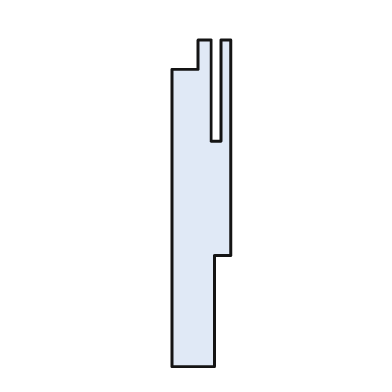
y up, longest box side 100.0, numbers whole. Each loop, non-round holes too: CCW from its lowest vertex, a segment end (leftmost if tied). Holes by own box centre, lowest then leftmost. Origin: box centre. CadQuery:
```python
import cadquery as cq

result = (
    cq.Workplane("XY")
    .moveTo(-9.0, -50.0)
    .lineTo(4.0, -50.0)
    .lineTo(4.0, -16.0)
    .lineTo(9.0, -16.0)
    .lineTo(9.0, 50.0)
    .lineTo(6.0, 50.0)
    .lineTo(6.0, 19.0)
    .lineTo(3.0, 19.0)
    .lineTo(3.0, 50.0)
    .lineTo(-1.0, 50.0)
    .lineTo(-1.0, 41.0)
    .lineTo(-9.0, 41.0)
    .close()
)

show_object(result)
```